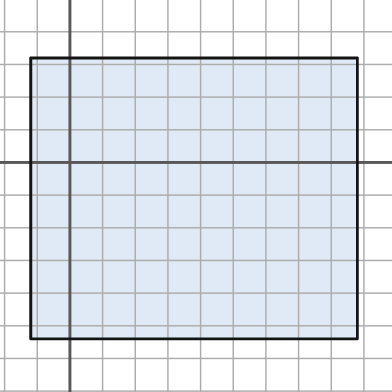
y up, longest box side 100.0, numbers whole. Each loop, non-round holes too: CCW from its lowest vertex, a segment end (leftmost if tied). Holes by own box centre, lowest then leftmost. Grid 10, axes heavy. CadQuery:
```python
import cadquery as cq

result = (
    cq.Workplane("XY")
    .moveTo(-12.0, -54.0)
    .lineTo(88.0, -54.0)
    .lineTo(88.0, 32.0)
    .lineTo(-12.0, 32.0)
    .close()
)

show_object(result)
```